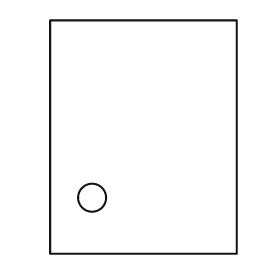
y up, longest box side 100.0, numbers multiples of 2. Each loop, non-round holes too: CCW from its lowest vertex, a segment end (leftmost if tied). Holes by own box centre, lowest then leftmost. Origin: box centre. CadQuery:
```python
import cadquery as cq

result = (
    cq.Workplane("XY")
    .moveTo(-40.0, -50.0)
    .lineTo(40.0, -50.0)
    .lineTo(40.0, 50.0)
    .lineTo(-40.0, 50.0)
    .close()
    .moveTo(-22.0, -26.0)
    .circle(6.0)
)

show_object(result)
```